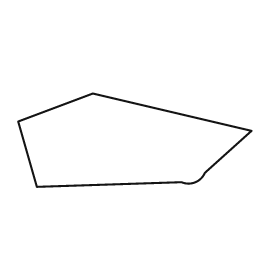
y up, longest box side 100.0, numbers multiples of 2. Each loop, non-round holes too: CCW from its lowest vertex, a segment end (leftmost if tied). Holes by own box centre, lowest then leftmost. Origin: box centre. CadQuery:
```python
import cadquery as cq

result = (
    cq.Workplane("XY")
    .moveTo(-42.0, -20.0)
    .lineTo(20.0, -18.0)
    .threePointArc((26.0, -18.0), (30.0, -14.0))
    .lineTo(50.0, 4.0)
    .lineTo(-18.0, 20.0)
    .lineTo(-50.0, 8.0)
    .close()
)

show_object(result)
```